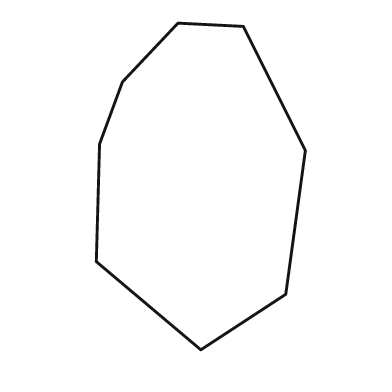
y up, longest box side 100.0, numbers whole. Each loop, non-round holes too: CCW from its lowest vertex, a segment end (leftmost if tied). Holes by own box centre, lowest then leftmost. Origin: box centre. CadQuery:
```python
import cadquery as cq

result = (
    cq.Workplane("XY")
    .moveTo(0.0, -50.0)
    .lineTo(26.0, -33.0)
    .lineTo(32.0, 11.0)
    .lineTo(13.0, 49.0)
    .lineTo(-7.0, 50.0)
    .lineTo(-24.0, 32.0)
    .lineTo(-31.0, 13.0)
    .lineTo(-32.0, -23.0)
    .close()
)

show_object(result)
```